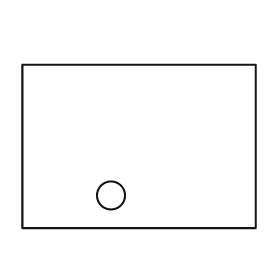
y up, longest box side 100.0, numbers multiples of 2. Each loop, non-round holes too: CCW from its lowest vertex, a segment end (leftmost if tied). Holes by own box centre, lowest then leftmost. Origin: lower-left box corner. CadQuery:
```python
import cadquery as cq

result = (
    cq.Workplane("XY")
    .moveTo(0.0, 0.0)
    .lineTo(100.0, 0.0)
    .lineTo(100.0, 70.0)
    .lineTo(0.0, 70.0)
    .close()
    .moveTo(38.0, 14.0)
    .circle(6.0)
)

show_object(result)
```